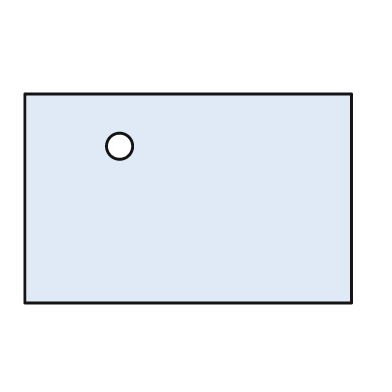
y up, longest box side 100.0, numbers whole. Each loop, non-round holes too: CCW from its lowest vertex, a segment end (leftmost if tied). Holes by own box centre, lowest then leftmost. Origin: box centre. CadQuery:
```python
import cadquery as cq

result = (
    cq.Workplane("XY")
    .moveTo(-50.0, -32.0)
    .lineTo(50.0, -32.0)
    .lineTo(50.0, 32.0)
    .lineTo(-50.0, 32.0)
    .close()
    .moveTo(-21.0, 16.0)
    .circle(4.0)
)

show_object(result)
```